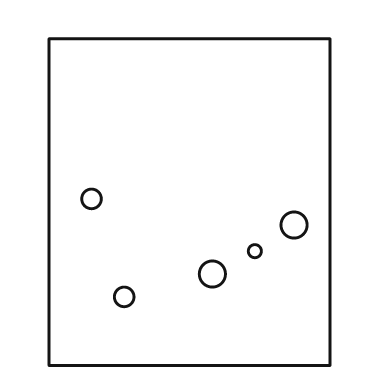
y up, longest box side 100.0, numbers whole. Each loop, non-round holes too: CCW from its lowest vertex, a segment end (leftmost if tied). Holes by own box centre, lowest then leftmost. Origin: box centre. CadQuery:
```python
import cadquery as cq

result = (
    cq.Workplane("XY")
    .moveTo(-43.0, -50.0)
    .lineTo(43.0, -50.0)
    .lineTo(43.0, 50.0)
    .lineTo(-43.0, 50.0)
    .close()
    .moveTo(-20.0, -29.0)
    .circle(3.0)
    .moveTo(7.0, -22.0)
    .circle(4.0)
    .moveTo(20.0, -15.0)
    .circle(2.0)
    .moveTo(32.0, -7.0)
    .circle(4.0)
    .moveTo(-30.0, 1.0)
    .circle(3.0)
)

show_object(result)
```